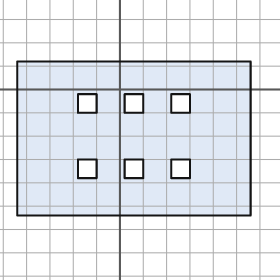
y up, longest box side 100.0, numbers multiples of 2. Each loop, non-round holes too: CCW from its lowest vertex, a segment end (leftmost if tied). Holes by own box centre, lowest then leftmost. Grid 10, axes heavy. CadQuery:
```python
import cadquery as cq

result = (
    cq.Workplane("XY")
    .moveTo(-44.0, -54.0)
    .lineTo(56.0, -54.0)
    .lineTo(56.0, 12.0)
    .lineTo(-44.0, 12.0)
    .close()
    .moveTo(-18.0, -38.0)
    .lineTo(-10.0, -38.0)
    .lineTo(-10.0, -30.0)
    .lineTo(-18.0, -30.0)
    .close()
    .moveTo(2.0, -38.0)
    .lineTo(10.0, -38.0)
    .lineTo(10.0, -30.0)
    .lineTo(2.0, -30.0)
    .close()
    .moveTo(22.0, -38.0)
    .lineTo(30.0, -38.0)
    .lineTo(30.0, -30.0)
    .lineTo(22.0, -30.0)
    .close()
    .moveTo(-18.0, -10.0)
    .lineTo(-10.0, -10.0)
    .lineTo(-10.0, -2.0)
    .lineTo(-18.0, -2.0)
    .close()
    .moveTo(2.0, -10.0)
    .lineTo(10.0, -10.0)
    .lineTo(10.0, -2.0)
    .lineTo(2.0, -2.0)
    .close()
    .moveTo(22.0, -10.0)
    .lineTo(30.0, -10.0)
    .lineTo(30.0, -2.0)
    .lineTo(22.0, -2.0)
    .close()
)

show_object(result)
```